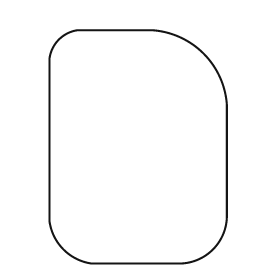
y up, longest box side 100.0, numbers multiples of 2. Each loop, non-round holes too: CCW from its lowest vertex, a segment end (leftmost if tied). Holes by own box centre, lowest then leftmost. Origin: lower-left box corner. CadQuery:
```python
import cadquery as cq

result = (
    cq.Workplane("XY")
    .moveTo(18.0, 0.0)
    .lineTo(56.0, 0.0)
    .threePointArc((70.0, 6.0), (76.0, 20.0))
    .lineTo(76.0, 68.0)
    .threePointArc((66.0, 90.0), (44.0, 100.0))
    .lineTo(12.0, 100.0)
    .threePointArc((4.0, 96.0), (0.0, 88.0))
    .lineTo(0.0, 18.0)
    .threePointArc((6.0, 6.0), (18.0, 0.0))
    .close()
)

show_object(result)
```